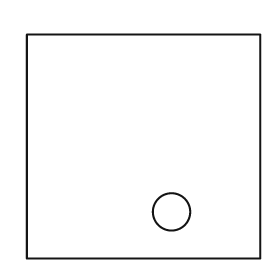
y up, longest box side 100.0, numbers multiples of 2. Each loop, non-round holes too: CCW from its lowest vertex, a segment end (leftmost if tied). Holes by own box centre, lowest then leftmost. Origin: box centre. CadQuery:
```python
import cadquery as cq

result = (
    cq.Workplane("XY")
    .moveTo(-50.0, -48.0)
    .lineTo(50.0, -48.0)
    .lineTo(50.0, 48.0)
    .lineTo(-50.0, 48.0)
    .close()
    .moveTo(12.0, -28.0)
    .circle(8.0)
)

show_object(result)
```